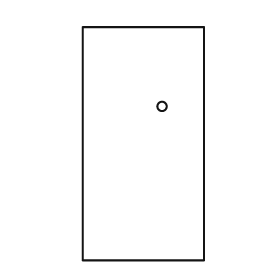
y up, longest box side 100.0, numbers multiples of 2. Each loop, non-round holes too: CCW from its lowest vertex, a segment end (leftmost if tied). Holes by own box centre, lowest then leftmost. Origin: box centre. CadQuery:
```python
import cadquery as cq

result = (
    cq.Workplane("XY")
    .moveTo(-26.0, -50.0)
    .lineTo(26.0, -50.0)
    .lineTo(26.0, 50.0)
    .lineTo(-26.0, 50.0)
    .close()
    .moveTo(8.0, 16.0)
    .circle(2.0)
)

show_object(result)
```